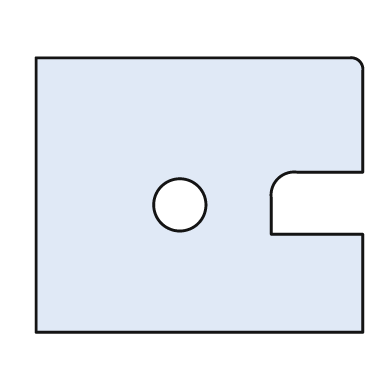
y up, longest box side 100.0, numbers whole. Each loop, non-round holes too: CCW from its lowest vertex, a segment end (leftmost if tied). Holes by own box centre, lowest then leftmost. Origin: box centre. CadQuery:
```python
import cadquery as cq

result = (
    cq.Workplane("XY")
    .moveTo(-50.0, -42.0)
    .lineTo(50.0, -42.0)
    .lineTo(50.0, -12.0)
    .lineTo(22.0, -12.0)
    .lineTo(22.0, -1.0)
    .threePointArc((24.0, 5.0), (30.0, 7.0))
    .lineTo(50.0, 7.0)
    .lineTo(50.0, 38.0)
    .threePointArc((49.0, 41.0), (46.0, 42.0))
    .lineTo(-50.0, 42.0)
    .close()
    .moveTo(-6.0, -3.0)
    .circle(8.0)
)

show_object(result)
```